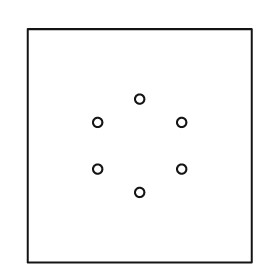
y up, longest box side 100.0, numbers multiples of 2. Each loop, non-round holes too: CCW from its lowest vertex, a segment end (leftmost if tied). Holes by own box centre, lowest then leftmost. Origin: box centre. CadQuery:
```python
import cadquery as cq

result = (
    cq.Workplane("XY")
    .moveTo(-48.0, -50.0)
    .lineTo(48.0, -50.0)
    .lineTo(48.0, 50.0)
    .lineTo(-48.0, 50.0)
    .close()
    .moveTo(0.0, -20.0)
    .circle(2.0)
    .moveTo(-18.0, -10.0)
    .circle(2.0)
    .moveTo(18.0, -10.0)
    .circle(2.0)
    .moveTo(-18.0, 10.0)
    .circle(2.0)
    .moveTo(18.0, 10.0)
    .circle(2.0)
    .moveTo(0.0, 20.0)
    .circle(2.0)
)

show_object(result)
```